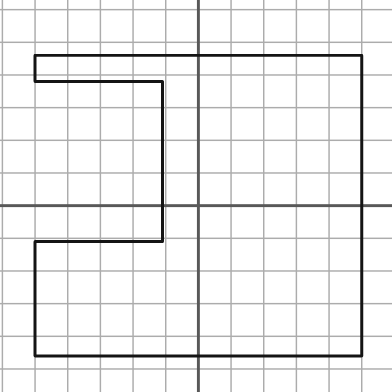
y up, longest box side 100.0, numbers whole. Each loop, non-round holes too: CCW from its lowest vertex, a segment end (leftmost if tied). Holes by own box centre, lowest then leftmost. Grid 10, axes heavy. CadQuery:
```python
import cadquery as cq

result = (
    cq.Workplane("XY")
    .moveTo(-50.0, -46.0)
    .lineTo(50.0, -46.0)
    .lineTo(50.0, 46.0)
    .lineTo(-50.0, 46.0)
    .lineTo(-50.0, 38.0)
    .lineTo(-11.0, 38.0)
    .lineTo(-11.0, -11.0)
    .lineTo(-50.0, -11.0)
    .close()
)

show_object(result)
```